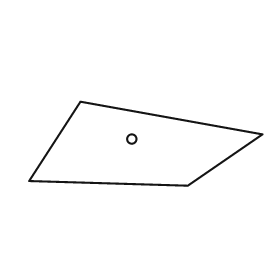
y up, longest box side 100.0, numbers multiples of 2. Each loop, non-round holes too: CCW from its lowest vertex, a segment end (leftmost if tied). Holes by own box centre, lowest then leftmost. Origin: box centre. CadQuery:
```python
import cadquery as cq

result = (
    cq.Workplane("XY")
    .moveTo(18.0, -18.0)
    .lineTo(50.0, 4.0)
    .lineTo(-28.0, 18.0)
    .lineTo(-50.0, -16.0)
    .close()
    .moveTo(-6.0, 2.0)
    .circle(2.0)
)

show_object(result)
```